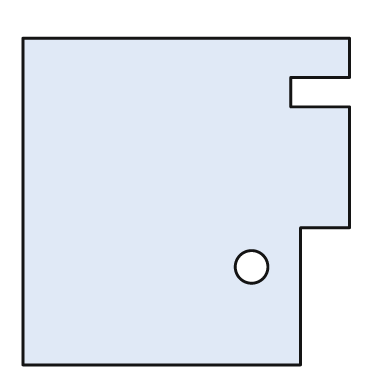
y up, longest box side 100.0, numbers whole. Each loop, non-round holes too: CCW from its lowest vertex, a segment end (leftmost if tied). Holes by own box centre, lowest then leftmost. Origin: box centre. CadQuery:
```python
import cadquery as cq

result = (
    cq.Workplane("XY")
    .moveTo(-50.0, -50.0)
    .lineTo(35.0, -50.0)
    .lineTo(35.0, -8.0)
    .lineTo(50.0, -8.0)
    .lineTo(50.0, 29.0)
    .lineTo(32.0, 29.0)
    .lineTo(32.0, 38.0)
    .lineTo(50.0, 38.0)
    .lineTo(50.0, 50.0)
    .lineTo(-50.0, 50.0)
    .close()
    .moveTo(20.0, -20.0)
    .circle(5.0)
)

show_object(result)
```